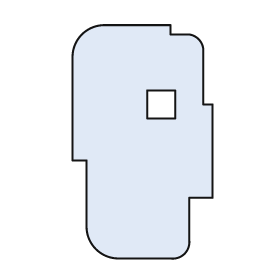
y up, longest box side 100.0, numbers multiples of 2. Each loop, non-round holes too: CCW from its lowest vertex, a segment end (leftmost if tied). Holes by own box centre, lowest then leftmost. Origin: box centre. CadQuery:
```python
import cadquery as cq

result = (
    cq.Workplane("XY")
    .moveTo(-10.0, -50.0)
    .lineTo(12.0, -50.0)
    .threePointArc((18.0, -48.0), (20.0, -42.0))
    .lineTo(20.0, -24.0)
    .lineTo(30.0, -24.0)
    .lineTo(30.0, 16.0)
    .lineTo(26.0, 16.0)
    .lineTo(26.0, 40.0)
    .threePointArc((24.0, 44.0), (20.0, 46.0))
    .lineTo(12.0, 46.0)
    .lineTo(12.0, 50.0)
    .lineTo(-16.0, 50.0)
    .threePointArc((-26.0, 46.0), (-30.0, 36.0))
    .lineTo(-30.0, -8.0)
    .lineTo(-24.0, -8.0)
    .lineTo(-24.0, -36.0)
    .threePointArc((-20.0, -46.0), (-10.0, -50.0))
    .close()
    .moveTo(2.0, 10.0)
    .lineTo(14.0, 10.0)
    .lineTo(14.0, 22.0)
    .lineTo(2.0, 22.0)
    .close()
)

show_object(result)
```